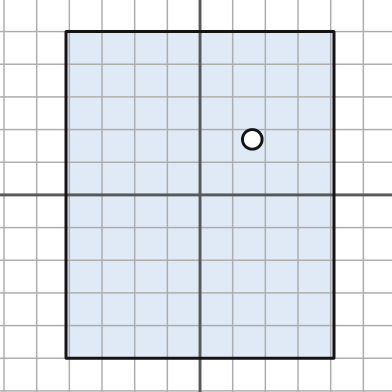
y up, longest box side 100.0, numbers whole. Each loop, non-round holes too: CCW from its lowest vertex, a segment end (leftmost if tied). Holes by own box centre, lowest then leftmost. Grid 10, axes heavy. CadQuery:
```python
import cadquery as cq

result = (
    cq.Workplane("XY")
    .moveTo(-41.0, -50.0)
    .lineTo(41.0, -50.0)
    .lineTo(41.0, 50.0)
    .lineTo(-41.0, 50.0)
    .close()
    .moveTo(16.0, 17.0)
    .circle(3.0)
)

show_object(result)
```